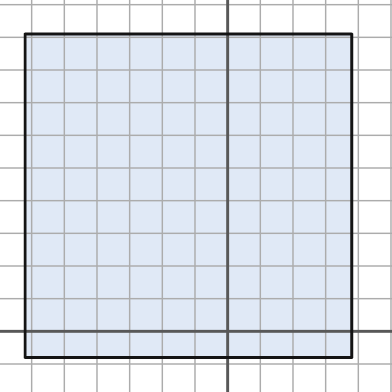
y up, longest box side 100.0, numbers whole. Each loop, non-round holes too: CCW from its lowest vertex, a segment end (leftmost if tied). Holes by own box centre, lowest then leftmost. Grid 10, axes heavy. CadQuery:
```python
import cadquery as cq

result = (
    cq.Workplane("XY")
    .moveTo(-62.0, -8.0)
    .lineTo(38.0, -8.0)
    .lineTo(38.0, 91.0)
    .lineTo(-62.0, 91.0)
    .close()
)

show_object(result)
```